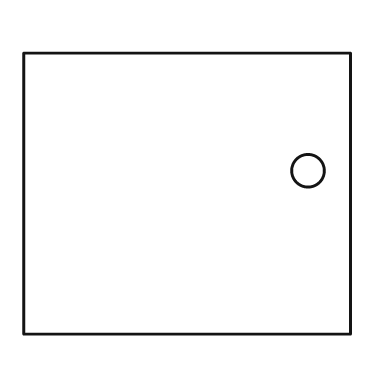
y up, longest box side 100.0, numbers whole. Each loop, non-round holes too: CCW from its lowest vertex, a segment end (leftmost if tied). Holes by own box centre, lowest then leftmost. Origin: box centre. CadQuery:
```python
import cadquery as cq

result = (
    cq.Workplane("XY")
    .moveTo(-50.0, -43.0)
    .lineTo(50.0, -43.0)
    .lineTo(50.0, 43.0)
    .lineTo(-50.0, 43.0)
    .close()
    .moveTo(37.0, 7.0)
    .circle(5.0)
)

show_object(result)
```